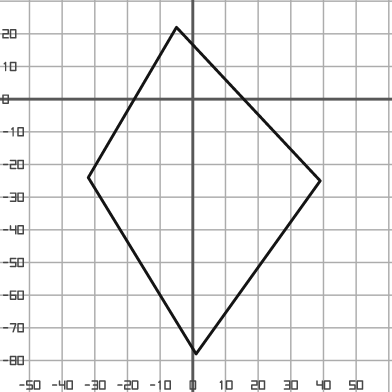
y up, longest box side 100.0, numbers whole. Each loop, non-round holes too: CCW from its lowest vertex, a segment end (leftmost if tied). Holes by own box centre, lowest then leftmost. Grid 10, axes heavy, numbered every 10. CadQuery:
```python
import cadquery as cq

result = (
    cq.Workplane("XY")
    .moveTo(1.0, -78.0)
    .lineTo(39.0, -25.0)
    .lineTo(-5.0, 22.0)
    .lineTo(-32.0, -24.0)
    .close()
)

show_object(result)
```